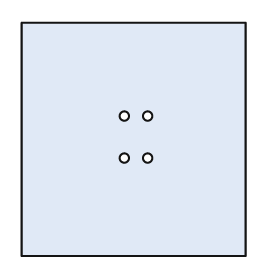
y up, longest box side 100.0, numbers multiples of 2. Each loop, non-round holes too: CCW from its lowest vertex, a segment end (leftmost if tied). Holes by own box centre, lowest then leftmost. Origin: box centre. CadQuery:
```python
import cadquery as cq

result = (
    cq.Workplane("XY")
    .moveTo(-48.0, -50.0)
    .lineTo(48.0, -50.0)
    .lineTo(48.0, 50.0)
    .lineTo(-48.0, 50.0)
    .close()
    .moveTo(-4.0, -8.0)
    .circle(2.0)
    .moveTo(6.0, -8.0)
    .circle(2.0)
    .moveTo(-4.0, 10.0)
    .circle(2.0)
    .moveTo(6.0, 10.0)
    .circle(2.0)
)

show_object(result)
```